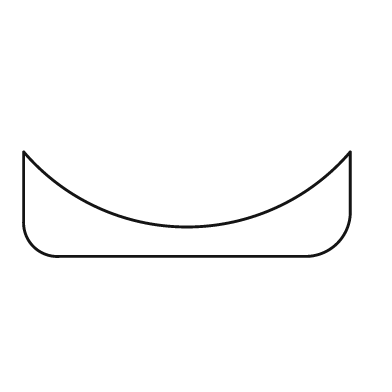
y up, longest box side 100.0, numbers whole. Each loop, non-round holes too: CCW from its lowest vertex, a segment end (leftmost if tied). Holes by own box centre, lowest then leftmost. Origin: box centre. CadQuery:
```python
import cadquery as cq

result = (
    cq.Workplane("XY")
    .moveTo(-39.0, -16.0)
    .lineTo(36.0, -16.0)
    .threePointArc((46.0, -12.0), (50.0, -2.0))
    .lineTo(50.0, 16.0)
    .threePointArc((0.0, -7.0), (-50.0, 16.0))
    .lineTo(-50.0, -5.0)
    .threePointArc((-47.0, -13.0), (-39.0, -16.0))
    .close()
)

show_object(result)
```